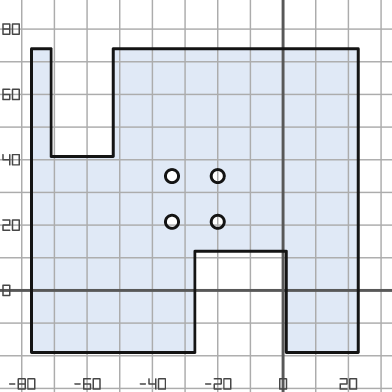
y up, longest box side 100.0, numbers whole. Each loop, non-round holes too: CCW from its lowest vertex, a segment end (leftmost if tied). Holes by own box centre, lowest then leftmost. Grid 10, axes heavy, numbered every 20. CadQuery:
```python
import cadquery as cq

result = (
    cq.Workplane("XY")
    .moveTo(-77.0, -19.0)
    .lineTo(-27.0, -19.0)
    .lineTo(-27.0, 12.0)
    .lineTo(1.0, 12.0)
    .lineTo(1.0, -19.0)
    .lineTo(23.0, -19.0)
    .lineTo(23.0, 74.0)
    .lineTo(-52.0, 74.0)
    .lineTo(-52.0, 41.0)
    .lineTo(-71.0, 41.0)
    .lineTo(-71.0, 74.0)
    .lineTo(-77.0, 74.0)
    .close()
    .moveTo(-34.0, 21.0)
    .circle(2.0)
    .moveTo(-20.0, 21.0)
    .circle(2.0)
    .moveTo(-34.0, 35.0)
    .circle(2.0)
    .moveTo(-20.0, 35.0)
    .circle(2.0)
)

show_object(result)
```